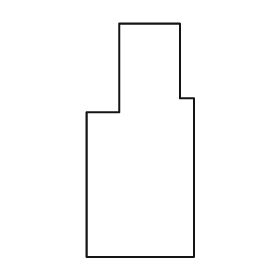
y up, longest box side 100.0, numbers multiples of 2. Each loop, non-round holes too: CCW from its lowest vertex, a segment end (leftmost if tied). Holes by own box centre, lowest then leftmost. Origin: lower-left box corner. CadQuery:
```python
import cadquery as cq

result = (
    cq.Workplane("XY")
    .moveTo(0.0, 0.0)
    .lineTo(46.0, 0.0)
    .lineTo(46.0, 68.0)
    .lineTo(40.0, 68.0)
    .lineTo(40.0, 100.0)
    .lineTo(14.0, 100.0)
    .lineTo(14.0, 62.0)
    .lineTo(0.0, 62.0)
    .close()
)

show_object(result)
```